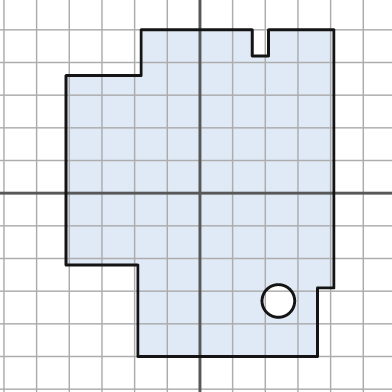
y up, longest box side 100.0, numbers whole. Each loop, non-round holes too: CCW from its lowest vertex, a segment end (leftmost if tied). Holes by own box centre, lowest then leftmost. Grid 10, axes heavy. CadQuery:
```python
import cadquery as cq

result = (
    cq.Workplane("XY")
    .moveTo(-19.0, -50.0)
    .lineTo(36.0, -50.0)
    .lineTo(36.0, -29.0)
    .lineTo(41.0, -29.0)
    .lineTo(41.0, 50.0)
    .lineTo(21.0, 50.0)
    .lineTo(21.0, 42.0)
    .lineTo(16.0, 42.0)
    .lineTo(16.0, 50.0)
    .lineTo(-18.0, 50.0)
    .lineTo(-18.0, 36.0)
    .lineTo(-41.0, 36.0)
    .lineTo(-41.0, -22.0)
    .lineTo(-19.0, -22.0)
    .close()
    .moveTo(24.0, -33.0)
    .circle(5.0)
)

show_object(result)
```